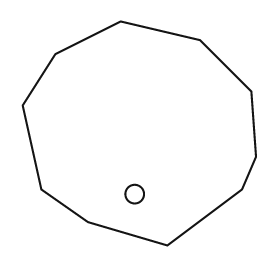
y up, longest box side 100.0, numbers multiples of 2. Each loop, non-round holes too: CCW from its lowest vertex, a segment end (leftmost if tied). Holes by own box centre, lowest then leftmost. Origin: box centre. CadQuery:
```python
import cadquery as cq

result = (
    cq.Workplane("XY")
    .moveTo(12.0, -48.0)
    .lineTo(44.0, -24.0)
    .lineTo(50.0, -10.0)
    .lineTo(48.0, 18.0)
    .lineTo(26.0, 40.0)
    .lineTo(-8.0, 48.0)
    .lineTo(-36.0, 34.0)
    .lineTo(-50.0, 12.0)
    .lineTo(-42.0, -24.0)
    .lineTo(-22.0, -38.0)
    .close()
    .moveTo(-2.0, -26.0)
    .circle(4.0)
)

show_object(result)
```